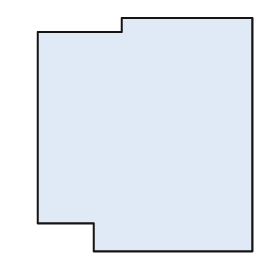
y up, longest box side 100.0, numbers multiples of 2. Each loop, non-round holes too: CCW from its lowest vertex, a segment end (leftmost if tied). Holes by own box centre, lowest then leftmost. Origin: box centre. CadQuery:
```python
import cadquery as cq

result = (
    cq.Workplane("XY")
    .moveTo(-22.0, -50.0)
    .lineTo(46.0, -50.0)
    .lineTo(46.0, 50.0)
    .lineTo(-10.0, 50.0)
    .lineTo(-10.0, 44.0)
    .lineTo(-46.0, 44.0)
    .lineTo(-46.0, -38.0)
    .lineTo(-22.0, -38.0)
    .close()
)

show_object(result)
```